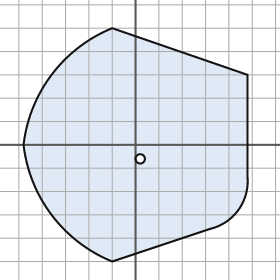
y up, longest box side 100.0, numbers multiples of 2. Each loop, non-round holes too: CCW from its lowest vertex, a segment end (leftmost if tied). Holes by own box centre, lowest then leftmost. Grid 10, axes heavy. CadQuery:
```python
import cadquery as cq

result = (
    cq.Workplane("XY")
    .moveTo(-10.0, -50.0)
    .lineTo(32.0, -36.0)
    .threePointArc((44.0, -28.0), (48.0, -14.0))
    .lineTo(48.0, 30.0)
    .lineTo(-10.0, 50.0)
    .threePointArc((-36.0, 30.0), (-48.0, 0.0))
    .threePointArc((-36.0, -30.0), (-10.0, -50.0))
    .close()
    .moveTo(2.0, -6.0)
    .circle(2.0)
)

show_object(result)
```